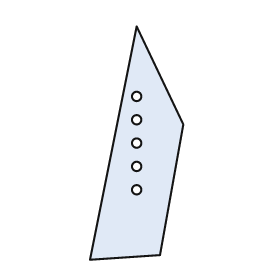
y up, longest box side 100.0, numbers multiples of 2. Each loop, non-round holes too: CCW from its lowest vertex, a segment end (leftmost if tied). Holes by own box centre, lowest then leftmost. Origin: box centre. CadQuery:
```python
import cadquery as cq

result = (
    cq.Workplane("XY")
    .moveTo(-20.0, -50.0)
    .lineTo(10.0, -48.0)
    .lineTo(20.0, 8.0)
    .lineTo(0.0, 50.0)
    .close()
    .moveTo(0.0, -20.0)
    .circle(2.0)
    .moveTo(0.0, -10.0)
    .circle(2.0)
    .moveTo(0.0, 0.0)
    .circle(2.0)
    .moveTo(0.0, 10.0)
    .circle(2.0)
    .moveTo(0.0, 20.0)
    .circle(2.0)
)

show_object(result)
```